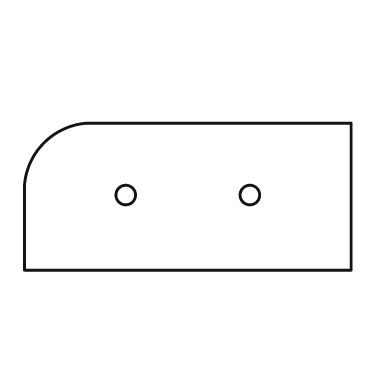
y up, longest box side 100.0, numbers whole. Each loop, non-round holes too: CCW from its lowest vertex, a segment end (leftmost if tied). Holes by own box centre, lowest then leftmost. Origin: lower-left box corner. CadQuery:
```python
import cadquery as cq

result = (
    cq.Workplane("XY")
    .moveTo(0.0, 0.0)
    .lineTo(100.0, 0.0)
    .lineTo(100.0, 45.0)
    .lineTo(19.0, 45.0)
    .threePointArc((6.0, 39.0), (0.0, 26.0))
    .close()
    .moveTo(31.0, 23.0)
    .circle(3.0)
    .moveTo(69.0, 23.0)
    .circle(3.0)
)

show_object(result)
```